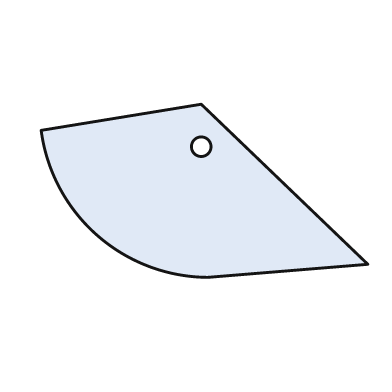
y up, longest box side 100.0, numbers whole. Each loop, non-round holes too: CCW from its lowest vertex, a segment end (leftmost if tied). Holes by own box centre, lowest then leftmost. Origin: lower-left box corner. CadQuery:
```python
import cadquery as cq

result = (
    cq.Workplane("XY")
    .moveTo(51.0, 0.0)
    .lineTo(100.0, 4.0)
    .lineTo(49.0, 53.0)
    .lineTo(0.0, 45.0)
    .threePointArc((17.0, 13.0), (51.0, 0.0))
    .close()
    .moveTo(49.0, 40.0)
    .circle(3.0)
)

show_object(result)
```